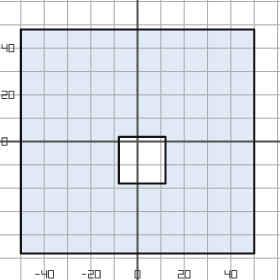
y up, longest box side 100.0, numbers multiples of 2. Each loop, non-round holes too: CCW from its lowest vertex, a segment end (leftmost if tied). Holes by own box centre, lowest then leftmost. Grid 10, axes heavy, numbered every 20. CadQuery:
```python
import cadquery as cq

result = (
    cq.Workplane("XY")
    .moveTo(-50.0, -48.0)
    .lineTo(50.0, -48.0)
    .lineTo(50.0, 48.0)
    .lineTo(-50.0, 48.0)
    .close()
    .moveTo(-8.0, -18.0)
    .lineTo(12.0, -18.0)
    .lineTo(12.0, 2.0)
    .lineTo(-8.0, 2.0)
    .close()
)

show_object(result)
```